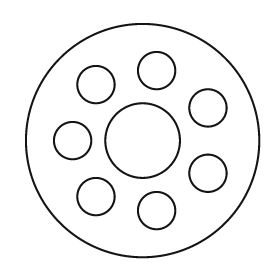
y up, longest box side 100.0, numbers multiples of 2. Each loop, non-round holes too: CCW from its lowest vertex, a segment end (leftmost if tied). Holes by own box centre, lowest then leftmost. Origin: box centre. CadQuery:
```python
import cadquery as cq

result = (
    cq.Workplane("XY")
    .moveTo(0.0, 0.0)
    .circle(50.0)
    .moveTo(6.0, -30.0)
    .circle(8.0)
    .moveTo(-20.0, -24.0)
    .circle(8.0)
    .moveTo(28.0, -14.0)
    .circle(8.0)
    .moveTo(-30.0, 0.0)
    .circle(8.0)
    .moveTo(0.0, 0.0)
    .circle(16.0)
    .moveTo(28.0, 14.0)
    .circle(8.0)
    .moveTo(-20.0, 24.0)
    .circle(8.0)
    .moveTo(6.0, 30.0)
    .circle(8.0)
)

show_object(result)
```